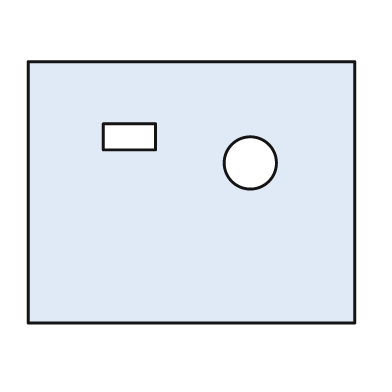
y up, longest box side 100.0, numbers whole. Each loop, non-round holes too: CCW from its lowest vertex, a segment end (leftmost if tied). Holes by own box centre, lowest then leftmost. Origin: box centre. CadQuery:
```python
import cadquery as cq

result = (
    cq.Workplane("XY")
    .moveTo(-50.0, -40.0)
    .lineTo(50.0, -40.0)
    .lineTo(50.0, 40.0)
    .lineTo(-50.0, 40.0)
    .close()
    .moveTo(18.0, 9.0)
    .circle(8.0)
    .moveTo(-27.0, 13.0)
    .lineTo(-11.0, 13.0)
    .lineTo(-11.0, 21.0)
    .lineTo(-27.0, 21.0)
    .close()
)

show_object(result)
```